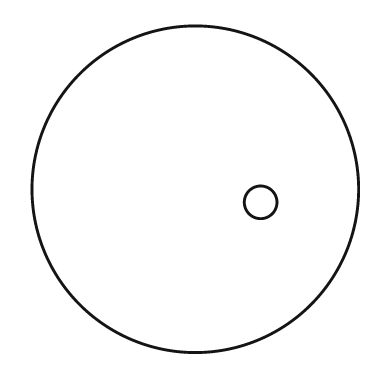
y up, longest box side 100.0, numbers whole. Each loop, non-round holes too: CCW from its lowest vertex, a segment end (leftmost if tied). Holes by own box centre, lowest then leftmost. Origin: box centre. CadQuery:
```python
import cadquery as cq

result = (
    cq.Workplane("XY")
    .moveTo(0.0, 0.0)
    .circle(50.0)
    .moveTo(20.0, -4.0)
    .circle(5.0)
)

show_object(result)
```